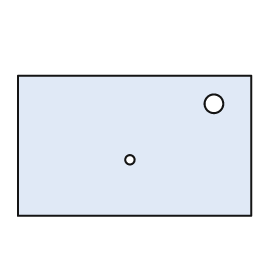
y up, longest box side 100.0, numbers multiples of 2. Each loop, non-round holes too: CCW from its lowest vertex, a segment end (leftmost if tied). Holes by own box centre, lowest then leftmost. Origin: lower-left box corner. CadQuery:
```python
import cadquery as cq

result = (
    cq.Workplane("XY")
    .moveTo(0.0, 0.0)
    .lineTo(100.0, 0.0)
    .lineTo(100.0, 60.0)
    .lineTo(0.0, 60.0)
    .close()
    .moveTo(48.0, 24.0)
    .circle(2.0)
    .moveTo(84.0, 48.0)
    .circle(4.0)
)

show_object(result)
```